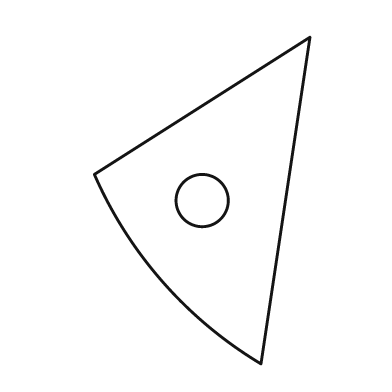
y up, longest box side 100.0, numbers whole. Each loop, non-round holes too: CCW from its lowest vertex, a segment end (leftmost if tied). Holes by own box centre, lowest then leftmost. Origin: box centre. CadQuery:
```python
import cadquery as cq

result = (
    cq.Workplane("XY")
    .moveTo(18.0, -50.0)
    .lineTo(33.0, 50.0)
    .lineTo(-33.0, 8.0)
    .threePointArc((-12.0, -25.0), (18.0, -50.0))
    .close()
    .moveTo(0.0, 0.0)
    .circle(8.0)
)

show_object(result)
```